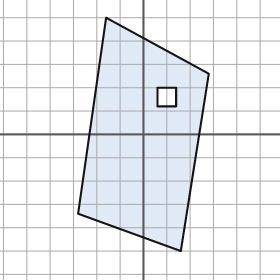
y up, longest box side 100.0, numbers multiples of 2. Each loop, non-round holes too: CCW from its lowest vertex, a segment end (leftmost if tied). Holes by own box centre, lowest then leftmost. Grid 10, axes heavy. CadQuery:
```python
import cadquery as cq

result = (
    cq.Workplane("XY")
    .moveTo(16.0, -50.0)
    .lineTo(28.0, 26.0)
    .lineTo(-16.0, 50.0)
    .lineTo(-28.0, -34.0)
    .close()
    .moveTo(6.0, 12.0)
    .lineTo(14.0, 12.0)
    .lineTo(14.0, 20.0)
    .lineTo(6.0, 20.0)
    .close()
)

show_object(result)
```